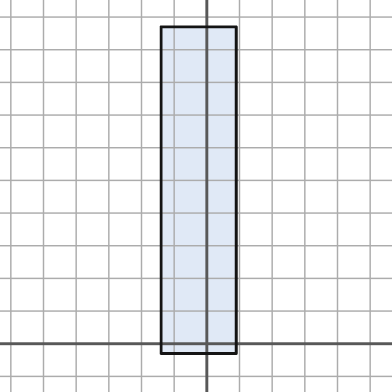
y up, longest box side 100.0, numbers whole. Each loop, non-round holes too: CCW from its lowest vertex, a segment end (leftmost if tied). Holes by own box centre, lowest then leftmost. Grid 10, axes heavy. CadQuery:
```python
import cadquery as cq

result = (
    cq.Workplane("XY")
    .moveTo(-14.0, -3.0)
    .lineTo(9.0, -3.0)
    .lineTo(9.0, 97.0)
    .lineTo(-14.0, 97.0)
    .close()
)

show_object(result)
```